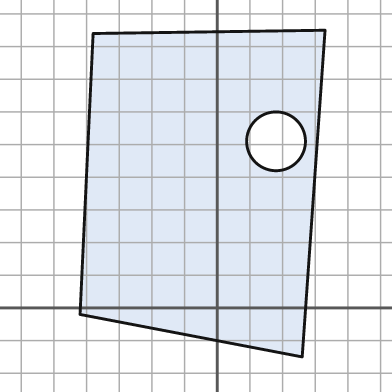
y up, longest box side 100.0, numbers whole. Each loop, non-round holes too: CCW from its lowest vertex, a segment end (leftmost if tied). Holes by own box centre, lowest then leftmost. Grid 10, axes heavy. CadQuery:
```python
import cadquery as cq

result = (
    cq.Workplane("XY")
    .moveTo(26.0, -15.0)
    .lineTo(33.0, 85.0)
    .lineTo(-38.0, 84.0)
    .lineTo(-42.0, -2.0)
    .close()
    .moveTo(18.0, 51.0)
    .circle(9.0)
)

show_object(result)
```